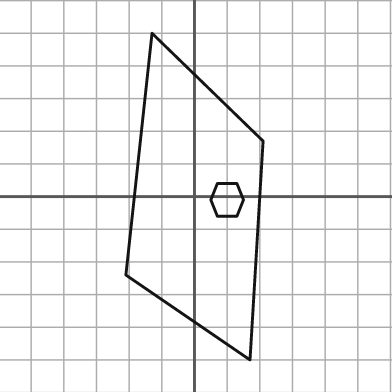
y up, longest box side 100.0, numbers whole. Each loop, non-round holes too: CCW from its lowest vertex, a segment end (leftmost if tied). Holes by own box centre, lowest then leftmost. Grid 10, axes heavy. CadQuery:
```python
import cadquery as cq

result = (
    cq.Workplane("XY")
    .moveTo(17.0, -50.0)
    .lineTo(21.0, 17.0)
    .lineTo(-13.0, 50.0)
    .lineTo(-21.0, -24.0)
    .close()
    .moveTo(7.0, -6.0)
    .lineTo(13.0, -6.0)
    .lineTo(15.0, -1.0)
    .lineTo(13.0, 4.0)
    .lineTo(7.0, 4.0)
    .lineTo(5.0, -1.0)
    .close()
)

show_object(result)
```